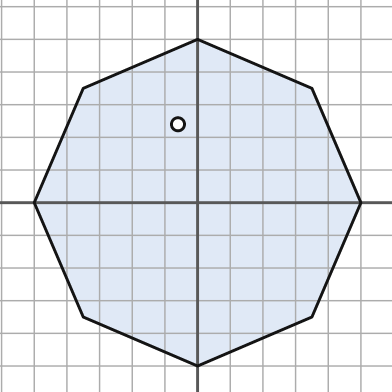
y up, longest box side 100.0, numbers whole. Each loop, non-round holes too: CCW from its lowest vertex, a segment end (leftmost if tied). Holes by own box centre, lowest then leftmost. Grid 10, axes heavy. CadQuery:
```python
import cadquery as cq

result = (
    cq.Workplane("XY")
    .moveTo(0.0, -50.0)
    .lineTo(35.0, -35.0)
    .lineTo(50.0, 0.0)
    .lineTo(35.0, 35.0)
    .lineTo(0.0, 50.0)
    .lineTo(-35.0, 35.0)
    .lineTo(-50.0, 0.0)
    .lineTo(-35.0, -35.0)
    .close()
    .moveTo(-6.0, 24.0)
    .circle(2.0)
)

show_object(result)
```